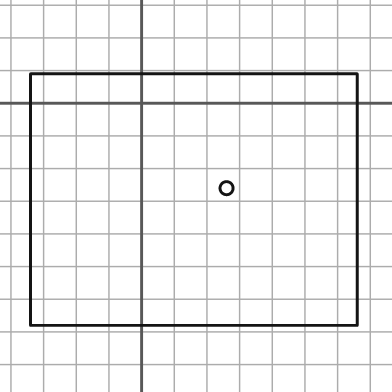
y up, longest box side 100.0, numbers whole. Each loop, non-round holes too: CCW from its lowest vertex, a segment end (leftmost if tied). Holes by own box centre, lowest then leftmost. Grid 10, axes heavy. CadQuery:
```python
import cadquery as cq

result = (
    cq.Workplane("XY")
    .moveTo(-34.0, -68.0)
    .lineTo(66.0, -68.0)
    .lineTo(66.0, 9.0)
    .lineTo(-34.0, 9.0)
    .close()
    .moveTo(26.0, -26.0)
    .circle(2.0)
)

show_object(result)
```